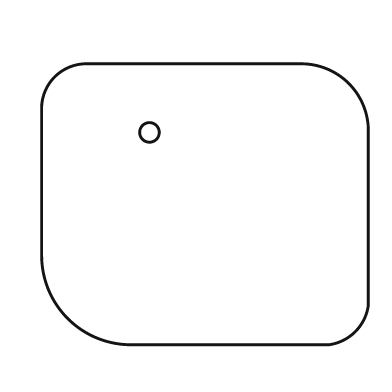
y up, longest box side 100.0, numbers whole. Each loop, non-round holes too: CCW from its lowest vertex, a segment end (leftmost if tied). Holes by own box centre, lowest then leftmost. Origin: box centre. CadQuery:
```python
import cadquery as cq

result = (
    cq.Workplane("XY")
    .moveTo(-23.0, -43.0)
    .lineTo(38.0, -43.0)
    .threePointArc((46.0, -39.0), (50.0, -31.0))
    .lineTo(50.0, 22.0)
    .threePointArc((44.0, 37.0), (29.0, 43.0))
    .lineTo(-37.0, 43.0)
    .threePointArc((-46.0, 39.0), (-50.0, 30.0))
    .lineTo(-50.0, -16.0)
    .threePointArc((-42.0, -35.0), (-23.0, -43.0))
    .close()
    .moveTo(-17.0, 22.0)
    .circle(3.0)
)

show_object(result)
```